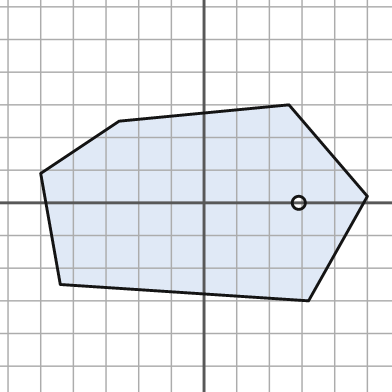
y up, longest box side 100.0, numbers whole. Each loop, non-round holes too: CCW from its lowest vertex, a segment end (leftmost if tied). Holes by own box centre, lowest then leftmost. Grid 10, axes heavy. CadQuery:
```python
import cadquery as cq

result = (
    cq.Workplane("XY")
    .moveTo(32.0, -30.0)
    .lineTo(50.0, 2.0)
    .lineTo(26.0, 30.0)
    .lineTo(-26.0, 25.0)
    .lineTo(-50.0, 9.0)
    .lineTo(-44.0, -25.0)
    .close()
    .moveTo(29.0, 0.0)
    .circle(2.0)
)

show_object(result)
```